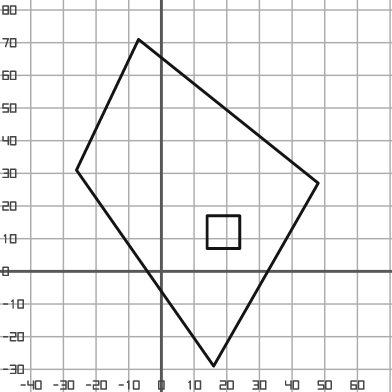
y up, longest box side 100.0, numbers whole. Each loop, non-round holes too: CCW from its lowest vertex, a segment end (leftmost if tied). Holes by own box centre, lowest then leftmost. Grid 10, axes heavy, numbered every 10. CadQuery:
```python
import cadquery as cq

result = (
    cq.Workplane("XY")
    .moveTo(16.0, -29.0)
    .lineTo(48.0, 27.0)
    .lineTo(-7.0, 71.0)
    .lineTo(-26.0, 31.0)
    .close()
    .moveTo(14.0, 7.0)
    .lineTo(24.0, 7.0)
    .lineTo(24.0, 17.0)
    .lineTo(14.0, 17.0)
    .close()
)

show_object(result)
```